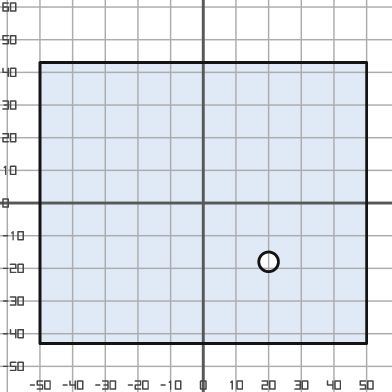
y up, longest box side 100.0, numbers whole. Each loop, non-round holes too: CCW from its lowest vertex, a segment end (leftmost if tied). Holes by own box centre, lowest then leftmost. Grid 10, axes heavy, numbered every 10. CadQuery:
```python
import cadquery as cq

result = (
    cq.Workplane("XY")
    .moveTo(-50.0, -43.0)
    .lineTo(50.0, -43.0)
    .lineTo(50.0, 43.0)
    .lineTo(-50.0, 43.0)
    .close()
    .moveTo(20.0, -18.0)
    .circle(3.0)
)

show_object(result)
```